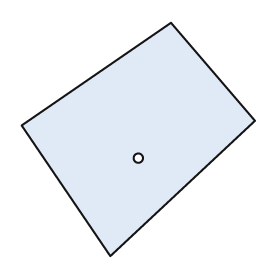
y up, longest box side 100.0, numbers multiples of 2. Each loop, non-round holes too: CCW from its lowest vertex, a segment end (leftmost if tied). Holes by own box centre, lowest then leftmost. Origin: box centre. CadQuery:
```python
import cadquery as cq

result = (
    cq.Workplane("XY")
    .moveTo(-12.0, -50.0)
    .lineTo(50.0, 8.0)
    .lineTo(14.0, 50.0)
    .lineTo(-50.0, 6.0)
    .close()
    .moveTo(0.0, -8.0)
    .circle(2.0)
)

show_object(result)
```